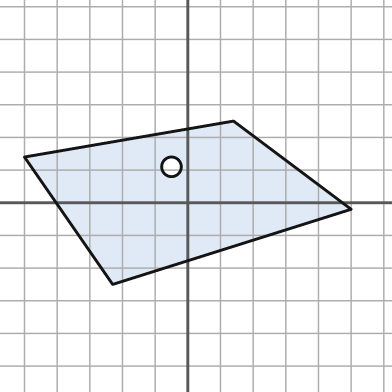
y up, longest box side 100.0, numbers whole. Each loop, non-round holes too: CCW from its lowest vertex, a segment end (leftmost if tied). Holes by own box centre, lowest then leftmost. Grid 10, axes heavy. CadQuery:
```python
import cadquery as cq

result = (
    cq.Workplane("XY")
    .moveTo(-23.0, -25.0)
    .lineTo(50.0, -2.0)
    .lineTo(14.0, 25.0)
    .lineTo(-50.0, 14.0)
    .close()
    .moveTo(-5.0, 11.0)
    .circle(3.0)
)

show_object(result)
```